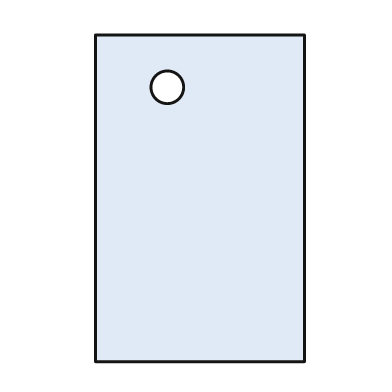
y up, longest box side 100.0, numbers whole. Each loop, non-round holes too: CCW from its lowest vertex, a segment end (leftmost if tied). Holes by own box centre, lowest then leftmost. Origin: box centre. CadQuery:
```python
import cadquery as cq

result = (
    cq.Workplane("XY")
    .moveTo(-32.0, -50.0)
    .lineTo(32.0, -50.0)
    .lineTo(32.0, 50.0)
    .lineTo(-32.0, 50.0)
    .close()
    .moveTo(-10.0, 34.0)
    .circle(5.0)
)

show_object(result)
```